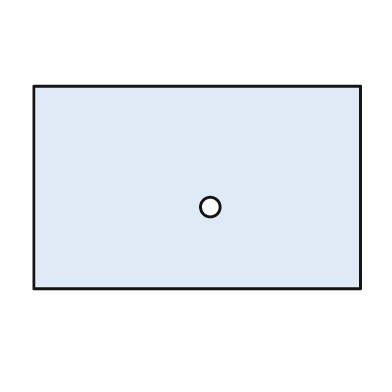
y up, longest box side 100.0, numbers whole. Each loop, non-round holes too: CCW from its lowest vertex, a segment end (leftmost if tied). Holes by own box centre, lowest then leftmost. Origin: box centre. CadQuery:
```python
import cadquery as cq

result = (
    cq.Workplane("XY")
    .moveTo(-50.0, -31.0)
    .lineTo(50.0, -31.0)
    .lineTo(50.0, 31.0)
    .lineTo(-50.0, 31.0)
    .close()
    .moveTo(4.0, -6.0)
    .circle(3.0)
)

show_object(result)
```